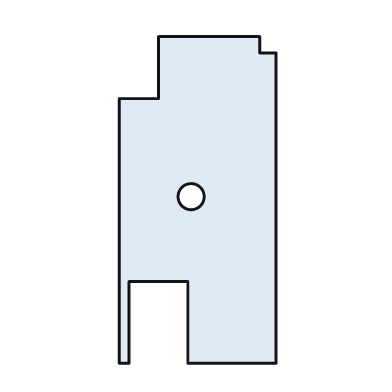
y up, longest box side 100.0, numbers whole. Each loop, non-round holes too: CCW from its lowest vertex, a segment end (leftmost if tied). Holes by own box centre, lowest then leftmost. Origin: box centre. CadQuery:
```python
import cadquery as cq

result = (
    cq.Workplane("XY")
    .moveTo(-24.0, -50.0)
    .lineTo(-21.0, -50.0)
    .lineTo(-21.0, -25.0)
    .lineTo(-3.0, -25.0)
    .lineTo(-3.0, -50.0)
    .lineTo(24.0, -50.0)
    .lineTo(24.0, 45.0)
    .lineTo(19.0, 45.0)
    .lineTo(19.0, 50.0)
    .lineTo(-12.0, 50.0)
    .lineTo(-12.0, 31.0)
    .lineTo(-24.0, 31.0)
    .close()
    .moveTo(-2.0, 1.0)
    .circle(4.0)
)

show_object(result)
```